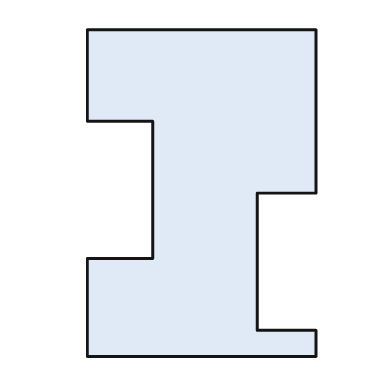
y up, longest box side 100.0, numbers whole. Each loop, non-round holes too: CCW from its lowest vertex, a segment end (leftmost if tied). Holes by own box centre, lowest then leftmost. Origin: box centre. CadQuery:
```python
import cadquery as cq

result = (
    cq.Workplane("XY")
    .moveTo(-35.0, -50.0)
    .lineTo(35.0, -50.0)
    .lineTo(35.0, -42.0)
    .lineTo(17.0, -42.0)
    .lineTo(17.0, 0.0)
    .lineTo(35.0, 0.0)
    .lineTo(35.0, 50.0)
    .lineTo(-35.0, 50.0)
    .lineTo(-35.0, 22.0)
    .lineTo(-15.0, 22.0)
    .lineTo(-15.0, -20.0)
    .lineTo(-35.0, -20.0)
    .close()
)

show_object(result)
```